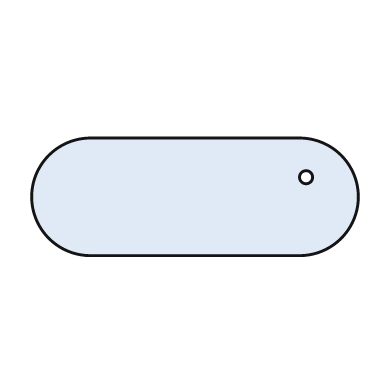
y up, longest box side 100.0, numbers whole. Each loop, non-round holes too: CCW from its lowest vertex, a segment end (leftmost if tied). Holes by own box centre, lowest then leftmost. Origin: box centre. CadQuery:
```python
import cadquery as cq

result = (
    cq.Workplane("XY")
    .moveTo(-32.0, -18.0)
    .lineTo(32.0, -18.0)
    .threePointArc((50.0, 0.0), (32.0, 18.0))
    .lineTo(-32.0, 18.0)
    .threePointArc((-50.0, 0.0), (-32.0, -18.0))
    .close()
    .moveTo(34.0, 6.0)
    .circle(2.0)
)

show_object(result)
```